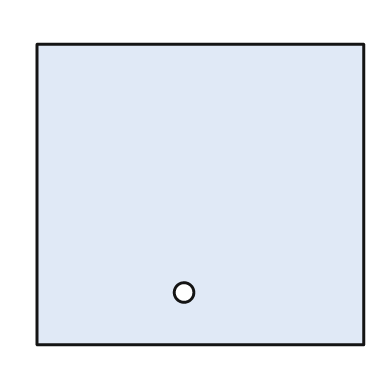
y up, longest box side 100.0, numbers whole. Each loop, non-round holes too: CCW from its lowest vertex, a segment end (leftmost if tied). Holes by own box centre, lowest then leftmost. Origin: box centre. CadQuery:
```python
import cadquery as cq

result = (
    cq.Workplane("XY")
    .moveTo(-50.0, -46.0)
    .lineTo(50.0, -46.0)
    .lineTo(50.0, 46.0)
    .lineTo(-50.0, 46.0)
    .close()
    .moveTo(-5.0, -30.0)
    .circle(3.0)
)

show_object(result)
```